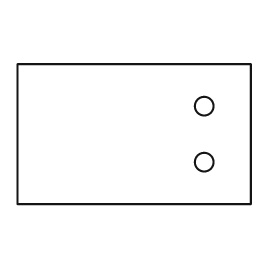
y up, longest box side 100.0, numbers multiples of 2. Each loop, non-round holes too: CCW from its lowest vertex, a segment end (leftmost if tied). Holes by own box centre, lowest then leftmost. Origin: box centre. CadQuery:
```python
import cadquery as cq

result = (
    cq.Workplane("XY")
    .moveTo(-50.0, -30.0)
    .lineTo(50.0, -30.0)
    .lineTo(50.0, 30.0)
    .lineTo(-50.0, 30.0)
    .close()
    .moveTo(30.0, -12.0)
    .circle(4.0)
    .moveTo(30.0, 12.0)
    .circle(4.0)
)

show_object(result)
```